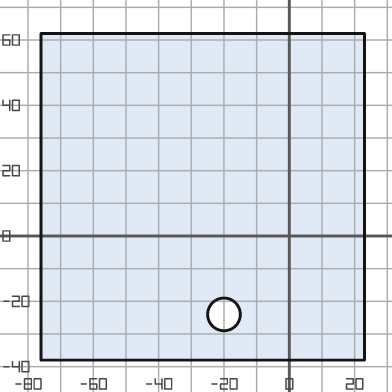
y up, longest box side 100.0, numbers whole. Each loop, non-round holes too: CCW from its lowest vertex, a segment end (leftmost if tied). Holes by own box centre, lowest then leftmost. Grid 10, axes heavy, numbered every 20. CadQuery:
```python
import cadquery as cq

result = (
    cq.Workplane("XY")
    .moveTo(-76.0, -38.0)
    .lineTo(23.0, -38.0)
    .lineTo(23.0, 62.0)
    .lineTo(-76.0, 62.0)
    .close()
    .moveTo(-20.0, -24.0)
    .circle(5.0)
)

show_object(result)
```